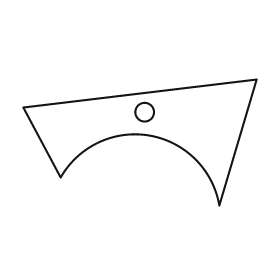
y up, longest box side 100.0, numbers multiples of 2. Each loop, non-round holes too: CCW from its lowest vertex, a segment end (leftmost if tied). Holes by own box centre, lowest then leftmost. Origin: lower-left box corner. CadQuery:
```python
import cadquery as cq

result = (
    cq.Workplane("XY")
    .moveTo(84.0, 0.0)
    .lineTo(100.0, 54.0)
    .lineTo(0.0, 42.0)
    .lineTo(16.0, 12.0)
    .threePointArc((54.0, 30.0), (84.0, 0.0))
    .close()
    .moveTo(52.0, 40.0)
    .circle(4.0)
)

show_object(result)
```